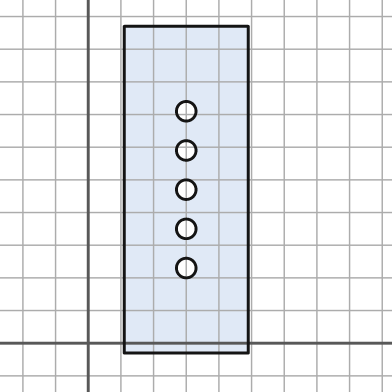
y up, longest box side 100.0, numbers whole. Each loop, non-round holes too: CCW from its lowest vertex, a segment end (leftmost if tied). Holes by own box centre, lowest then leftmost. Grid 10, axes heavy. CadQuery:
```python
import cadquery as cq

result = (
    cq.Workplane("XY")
    .moveTo(11.0, -3.0)
    .lineTo(49.0, -3.0)
    .lineTo(49.0, 97.0)
    .lineTo(11.0, 97.0)
    .close()
    .moveTo(30.0, 23.0)
    .circle(3.0)
    .moveTo(30.0, 35.0)
    .circle(3.0)
    .moveTo(30.0, 47.0)
    .circle(3.0)
    .moveTo(30.0, 59.0)
    .circle(3.0)
    .moveTo(30.0, 71.0)
    .circle(3.0)
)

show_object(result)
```